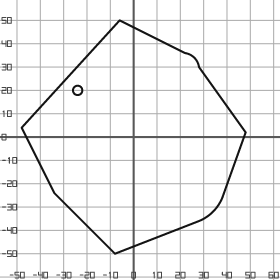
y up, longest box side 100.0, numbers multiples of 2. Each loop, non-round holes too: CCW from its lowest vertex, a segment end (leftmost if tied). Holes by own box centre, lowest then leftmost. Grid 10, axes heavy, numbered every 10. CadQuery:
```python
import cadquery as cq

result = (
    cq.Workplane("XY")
    .moveTo(-8.0, -50.0)
    .lineTo(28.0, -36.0)
    .threePointArc((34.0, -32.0), (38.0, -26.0))
    .lineTo(48.0, 2.0)
    .lineTo(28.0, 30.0)
    .threePointArc((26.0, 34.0), (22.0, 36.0))
    .lineTo(-6.0, 50.0)
    .lineTo(-48.0, 4.0)
    .lineTo(-34.0, -24.0)
    .close()
    .moveTo(-24.0, 20.0)
    .circle(2.0)
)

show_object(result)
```